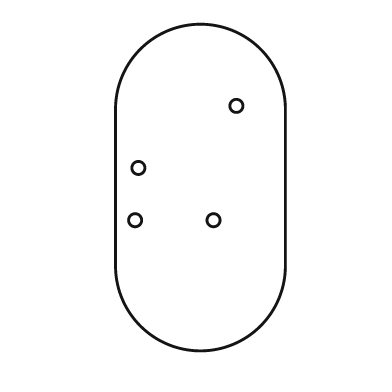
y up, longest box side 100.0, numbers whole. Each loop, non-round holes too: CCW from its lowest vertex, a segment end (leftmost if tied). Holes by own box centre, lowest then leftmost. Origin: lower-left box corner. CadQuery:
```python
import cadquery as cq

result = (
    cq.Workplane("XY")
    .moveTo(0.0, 26.0)
    .threePointArc((26.0, 0.0), (52.0, 26.0))
    .lineTo(52.0, 74.0)
    .threePointArc((26.0, 100.0), (0.0, 74.0))
    .close()
    .moveTo(6.0, 40.0)
    .circle(2.0)
    .moveTo(30.0, 40.0)
    .circle(2.0)
    .moveTo(7.0, 56.0)
    .circle(2.0)
    .moveTo(37.0, 75.0)
    .circle(2.0)
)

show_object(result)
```